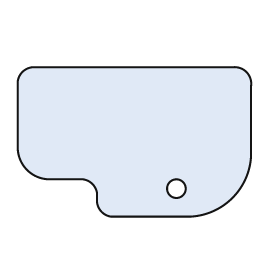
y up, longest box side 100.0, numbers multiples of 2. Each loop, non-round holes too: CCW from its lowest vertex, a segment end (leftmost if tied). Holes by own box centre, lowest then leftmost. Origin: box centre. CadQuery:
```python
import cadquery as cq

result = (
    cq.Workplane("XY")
    .moveTo(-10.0, -32.0)
    .lineTo(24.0, -32.0)
    .threePointArc((42.0, -24.0), (50.0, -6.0))
    .lineTo(50.0, 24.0)
    .threePointArc((48.0, 30.0), (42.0, 32.0))
    .lineTo(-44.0, 32.0)
    .threePointArc((-48.0, 30.0), (-50.0, 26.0))
    .lineTo(-50.0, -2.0)
    .threePointArc((-46.0, -12.0), (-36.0, -16.0))
    .lineTo(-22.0, -16.0)
    .threePointArc((-18.0, -18.0), (-16.0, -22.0))
    .lineTo(-16.0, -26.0)
    .threePointArc((-14.0, -30.0), (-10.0, -32.0))
    .close()
    .moveTo(18.0, -20.0)
    .circle(4.0)
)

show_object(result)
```